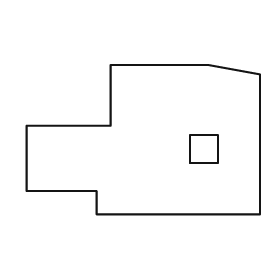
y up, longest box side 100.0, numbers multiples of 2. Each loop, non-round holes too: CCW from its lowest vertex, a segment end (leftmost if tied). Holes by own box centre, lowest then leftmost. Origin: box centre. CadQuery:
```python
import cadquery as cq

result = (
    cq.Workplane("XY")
    .moveTo(-20.0, -32.0)
    .lineTo(50.0, -32.0)
    .lineTo(50.0, 28.0)
    .lineTo(28.0, 32.0)
    .lineTo(-14.0, 32.0)
    .lineTo(-14.0, 6.0)
    .lineTo(-50.0, 6.0)
    .lineTo(-50.0, -22.0)
    .lineTo(-20.0, -22.0)
    .close()
    .moveTo(20.0, -10.0)
    .lineTo(32.0, -10.0)
    .lineTo(32.0, 2.0)
    .lineTo(20.0, 2.0)
    .close()
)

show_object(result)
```